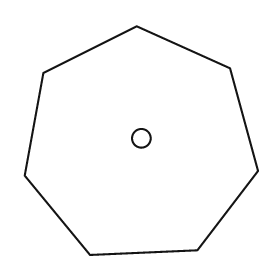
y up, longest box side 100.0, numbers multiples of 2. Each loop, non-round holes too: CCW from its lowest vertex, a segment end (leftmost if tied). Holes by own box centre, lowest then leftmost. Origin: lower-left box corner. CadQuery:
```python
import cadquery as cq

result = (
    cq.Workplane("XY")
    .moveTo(28.0, 0.0)
    .lineTo(74.0, 2.0)
    .lineTo(100.0, 36.0)
    .lineTo(88.0, 80.0)
    .lineTo(48.0, 98.0)
    .lineTo(8.0, 78.0)
    .lineTo(0.0, 34.0)
    .close()
    .moveTo(50.0, 50.0)
    .circle(4.0)
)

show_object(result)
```